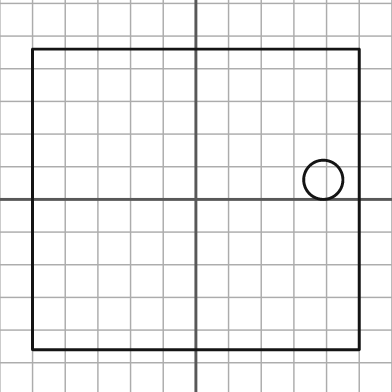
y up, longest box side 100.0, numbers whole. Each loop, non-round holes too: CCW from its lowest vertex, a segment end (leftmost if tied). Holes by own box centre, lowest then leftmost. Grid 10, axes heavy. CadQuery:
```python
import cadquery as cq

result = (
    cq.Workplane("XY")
    .moveTo(-50.0, -46.0)
    .lineTo(50.0, -46.0)
    .lineTo(50.0, 46.0)
    .lineTo(-50.0, 46.0)
    .close()
    .moveTo(39.0, 6.0)
    .circle(6.0)
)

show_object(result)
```